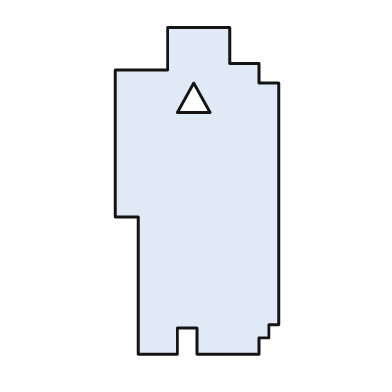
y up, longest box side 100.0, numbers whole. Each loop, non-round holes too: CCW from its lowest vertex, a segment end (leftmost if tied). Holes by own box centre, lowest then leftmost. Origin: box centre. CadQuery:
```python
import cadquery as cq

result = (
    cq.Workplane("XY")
    .moveTo(-18.0, -50.0)
    .lineTo(-6.0, -50.0)
    .lineTo(-6.0, -42.0)
    .lineTo(0.0, -42.0)
    .lineTo(0.0, -50.0)
    .lineTo(19.0, -50.0)
    .lineTo(19.0, -45.0)
    .lineTo(22.0, -45.0)
    .lineTo(22.0, -41.0)
    .lineTo(25.0, -41.0)
    .lineTo(25.0, 33.0)
    .lineTo(19.0, 33.0)
    .lineTo(19.0, 39.0)
    .lineTo(10.0, 39.0)
    .lineTo(10.0, 50.0)
    .lineTo(-9.0, 50.0)
    .lineTo(-9.0, 37.0)
    .lineTo(-25.0, 37.0)
    .lineTo(-25.0, -8.0)
    .lineTo(-18.0, -8.0)
    .close()
    .moveTo(-6.0, 24.0)
    .lineTo(4.0, 24.0)
    .lineTo(-1.0, 33.0)
    .close()
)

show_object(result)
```